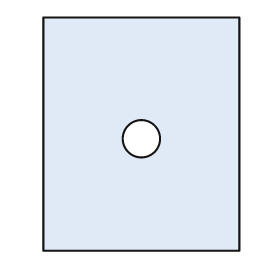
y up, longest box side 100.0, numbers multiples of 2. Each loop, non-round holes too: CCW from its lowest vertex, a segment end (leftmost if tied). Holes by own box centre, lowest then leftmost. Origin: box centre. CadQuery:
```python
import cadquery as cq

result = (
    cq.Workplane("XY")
    .moveTo(-42.0, -50.0)
    .lineTo(42.0, -50.0)
    .lineTo(42.0, 50.0)
    .lineTo(-42.0, 50.0)
    .close()
    .moveTo(0.0, -2.0)
    .circle(8.0)
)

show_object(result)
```